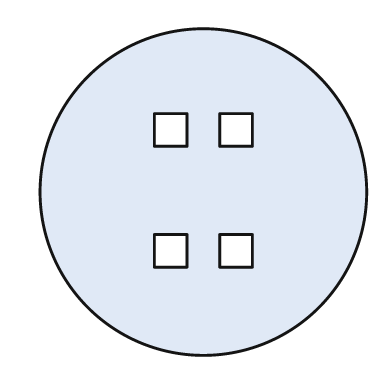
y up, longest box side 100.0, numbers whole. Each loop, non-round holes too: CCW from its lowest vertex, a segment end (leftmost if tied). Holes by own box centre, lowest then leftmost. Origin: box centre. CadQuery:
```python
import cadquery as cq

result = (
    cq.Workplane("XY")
    .moveTo(0.0, 0.0)
    .circle(50.0)
    .moveTo(-15.0, -23.0)
    .lineTo(-5.0, -23.0)
    .lineTo(-5.0, -13.0)
    .lineTo(-15.0, -13.0)
    .close()
    .moveTo(5.0, -23.0)
    .lineTo(15.0, -23.0)
    .lineTo(15.0, -13.0)
    .lineTo(5.0, -13.0)
    .close()
    .moveTo(-15.0, 14.0)
    .lineTo(-5.0, 14.0)
    .lineTo(-5.0, 24.0)
    .lineTo(-15.0, 24.0)
    .close()
    .moveTo(5.0, 14.0)
    .lineTo(15.0, 14.0)
    .lineTo(15.0, 24.0)
    .lineTo(5.0, 24.0)
    .close()
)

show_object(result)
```